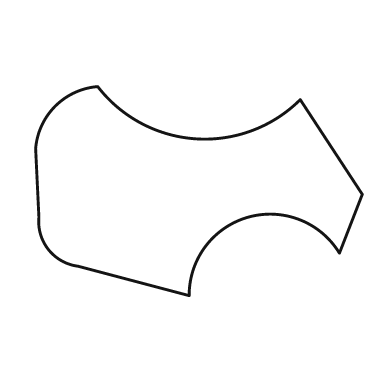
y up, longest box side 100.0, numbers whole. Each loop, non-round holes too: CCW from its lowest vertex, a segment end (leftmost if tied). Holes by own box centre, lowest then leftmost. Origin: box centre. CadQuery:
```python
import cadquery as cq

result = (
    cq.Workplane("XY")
    .moveTo(-3.0, -32.0)
    .threePointArc((15.0, -8.0), (43.0, -19.0))
    .lineTo(50.0, -1.0)
    .lineTo(31.0, 28.0)
    .threePointArc((-1.0, 16.0), (-31.0, 32.0))
    .threePointArc((-44.0, 26.0), (-50.0, 13.0))
    .lineTo(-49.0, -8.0)
    .threePointArc((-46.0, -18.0), (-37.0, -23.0))
    .close()
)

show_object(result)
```